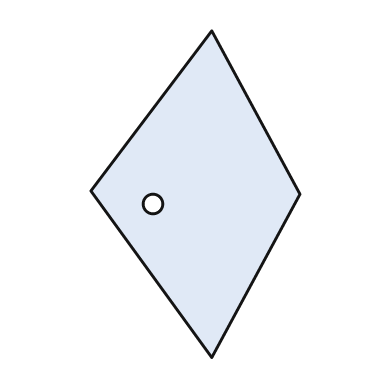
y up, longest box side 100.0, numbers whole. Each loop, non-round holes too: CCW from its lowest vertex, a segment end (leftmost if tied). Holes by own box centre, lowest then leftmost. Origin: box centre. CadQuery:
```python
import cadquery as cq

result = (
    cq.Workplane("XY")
    .moveTo(5.0, -50.0)
    .lineTo(32.0, 0.0)
    .lineTo(5.0, 50.0)
    .lineTo(-32.0, 1.0)
    .close()
    .moveTo(-13.0, -3.0)
    .circle(3.0)
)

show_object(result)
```